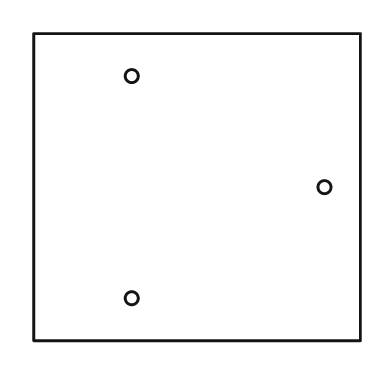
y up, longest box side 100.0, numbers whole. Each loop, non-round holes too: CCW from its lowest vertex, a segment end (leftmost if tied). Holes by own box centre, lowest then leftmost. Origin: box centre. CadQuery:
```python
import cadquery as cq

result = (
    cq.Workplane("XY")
    .moveTo(-50.0, -47.0)
    .lineTo(50.0, -47.0)
    .lineTo(50.0, 47.0)
    .lineTo(-50.0, 47.0)
    .close()
    .moveTo(-20.0, -34.0)
    .circle(2.0)
    .moveTo(39.0, 0.0)
    .circle(2.0)
    .moveTo(-20.0, 34.0)
    .circle(2.0)
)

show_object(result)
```